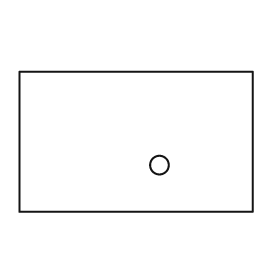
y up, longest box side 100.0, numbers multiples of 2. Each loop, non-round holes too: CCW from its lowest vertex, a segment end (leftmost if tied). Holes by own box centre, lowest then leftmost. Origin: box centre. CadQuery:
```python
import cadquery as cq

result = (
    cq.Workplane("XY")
    .moveTo(-50.0, -30.0)
    .lineTo(50.0, -30.0)
    .lineTo(50.0, 30.0)
    .lineTo(-50.0, 30.0)
    .close()
    .moveTo(10.0, -10.0)
    .circle(4.0)
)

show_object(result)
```